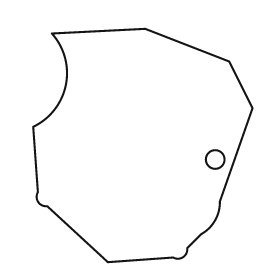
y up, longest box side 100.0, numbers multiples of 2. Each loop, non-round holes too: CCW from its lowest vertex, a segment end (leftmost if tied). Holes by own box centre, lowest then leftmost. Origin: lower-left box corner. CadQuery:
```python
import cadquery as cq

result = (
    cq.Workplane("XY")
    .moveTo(32.0, 0.0)
    .lineTo(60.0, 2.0)
    .threePointArc((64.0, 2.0), (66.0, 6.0))
    .lineTo(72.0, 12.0)
    .threePointArc((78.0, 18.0), (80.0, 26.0))
    .lineTo(94.0, 66.0)
    .lineTo(84.0, 86.0)
    .lineTo(48.0, 100.0)
    .lineTo(8.0, 98.0)
    .threePointArc((14.0, 76.0), (0.0, 58.0))
    .lineTo(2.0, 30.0)
    .threePointArc((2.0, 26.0), (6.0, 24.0))
    .close()
    .moveTo(78.0, 44.0)
    .circle(4.0)
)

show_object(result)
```